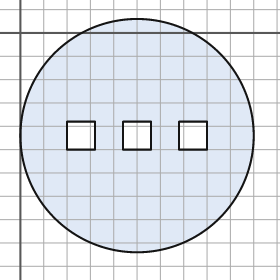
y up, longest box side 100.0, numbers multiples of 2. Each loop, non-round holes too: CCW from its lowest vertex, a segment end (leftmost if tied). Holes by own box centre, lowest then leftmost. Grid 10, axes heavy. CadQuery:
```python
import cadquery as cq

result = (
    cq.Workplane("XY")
    .moveTo(50.0, -44.0)
    .circle(50.0)
    .moveTo(20.0, -50.0)
    .lineTo(32.0, -50.0)
    .lineTo(32.0, -38.0)
    .lineTo(20.0, -38.0)
    .close()
    .moveTo(44.0, -50.0)
    .lineTo(56.0, -50.0)
    .lineTo(56.0, -38.0)
    .lineTo(44.0, -38.0)
    .close()
    .moveTo(68.0, -50.0)
    .lineTo(80.0, -50.0)
    .lineTo(80.0, -38.0)
    .lineTo(68.0, -38.0)
    .close()
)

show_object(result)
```